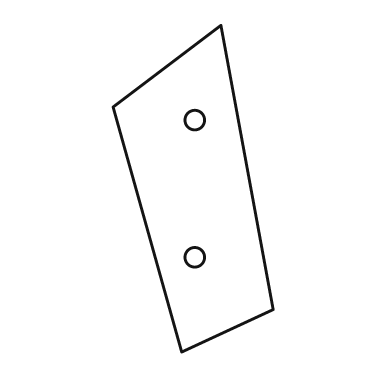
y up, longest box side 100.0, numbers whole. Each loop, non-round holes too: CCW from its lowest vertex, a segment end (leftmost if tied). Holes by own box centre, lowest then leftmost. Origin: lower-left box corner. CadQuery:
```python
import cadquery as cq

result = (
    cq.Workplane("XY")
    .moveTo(21.0, 0.0)
    .lineTo(49.0, 13.0)
    .lineTo(33.0, 100.0)
    .lineTo(0.0, 75.0)
    .close()
    .moveTo(25.0, 29.0)
    .circle(3.0)
    .moveTo(25.0, 71.0)
    .circle(3.0)
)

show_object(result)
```